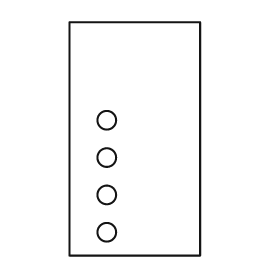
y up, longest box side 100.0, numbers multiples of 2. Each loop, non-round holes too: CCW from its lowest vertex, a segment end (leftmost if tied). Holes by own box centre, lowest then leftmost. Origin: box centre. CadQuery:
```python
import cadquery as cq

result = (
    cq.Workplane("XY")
    .moveTo(-28.0, -50.0)
    .lineTo(28.0, -50.0)
    .lineTo(28.0, 50.0)
    .lineTo(-28.0, 50.0)
    .close()
    .moveTo(-12.0, -40.0)
    .circle(4.0)
    .moveTo(-12.0, -24.0)
    .circle(4.0)
    .moveTo(-12.0, -8.0)
    .circle(4.0)
    .moveTo(-12.0, 8.0)
    .circle(4.0)
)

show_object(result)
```